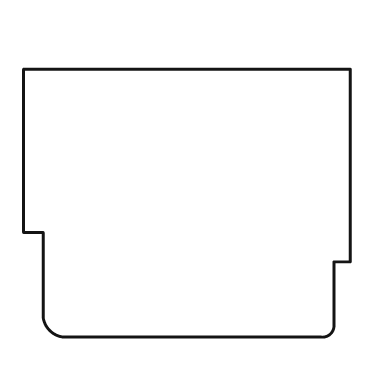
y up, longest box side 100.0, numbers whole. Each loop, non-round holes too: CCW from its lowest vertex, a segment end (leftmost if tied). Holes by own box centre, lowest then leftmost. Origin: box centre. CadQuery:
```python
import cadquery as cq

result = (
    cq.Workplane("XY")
    .moveTo(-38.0, -41.0)
    .lineTo(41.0, -41.0)
    .threePointArc((44.0, -40.0), (45.0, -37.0))
    .lineTo(45.0, -18.0)
    .lineTo(50.0, -18.0)
    .lineTo(50.0, 41.0)
    .lineTo(-50.0, 41.0)
    .lineTo(-50.0, -9.0)
    .lineTo(-44.0, -9.0)
    .lineTo(-44.0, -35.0)
    .threePointArc((-42.0, -39.0), (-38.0, -41.0))
    .close()
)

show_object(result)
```